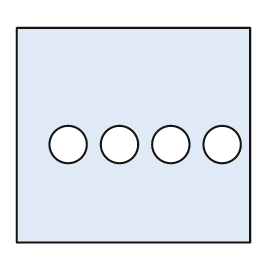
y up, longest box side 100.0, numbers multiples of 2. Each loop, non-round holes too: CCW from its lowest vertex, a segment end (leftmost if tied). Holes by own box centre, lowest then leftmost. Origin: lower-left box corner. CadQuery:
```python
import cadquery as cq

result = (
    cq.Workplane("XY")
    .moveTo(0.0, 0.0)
    .lineTo(100.0, 0.0)
    .lineTo(100.0, 92.0)
    .lineTo(0.0, 92.0)
    .close()
    .moveTo(22.0, 42.0)
    .circle(8.0)
    .moveTo(44.0, 42.0)
    .circle(8.0)
    .moveTo(66.0, 42.0)
    .circle(8.0)
    .moveTo(88.0, 42.0)
    .circle(8.0)
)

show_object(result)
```